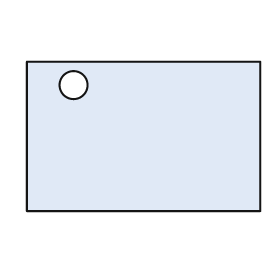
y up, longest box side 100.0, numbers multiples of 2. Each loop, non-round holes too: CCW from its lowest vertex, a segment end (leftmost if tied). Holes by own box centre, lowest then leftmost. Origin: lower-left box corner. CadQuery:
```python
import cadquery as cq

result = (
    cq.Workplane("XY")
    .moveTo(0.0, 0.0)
    .lineTo(100.0, 0.0)
    .lineTo(100.0, 64.0)
    .lineTo(0.0, 64.0)
    .close()
    .moveTo(20.0, 54.0)
    .circle(6.0)
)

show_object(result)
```